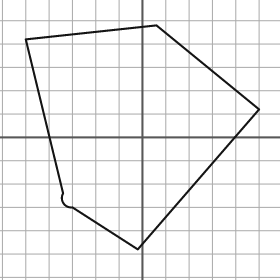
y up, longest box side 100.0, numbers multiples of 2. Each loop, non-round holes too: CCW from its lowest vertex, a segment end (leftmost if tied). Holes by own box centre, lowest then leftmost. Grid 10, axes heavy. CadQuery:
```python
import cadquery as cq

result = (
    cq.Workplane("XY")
    .moveTo(-2.0, -48.0)
    .lineTo(50.0, 12.0)
    .lineTo(6.0, 48.0)
    .lineTo(-50.0, 42.0)
    .lineTo(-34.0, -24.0)
    .threePointArc((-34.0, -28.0), (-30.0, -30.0))
    .close()
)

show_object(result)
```